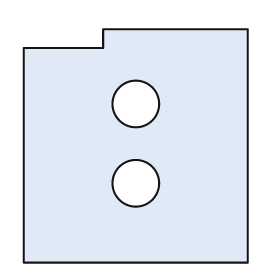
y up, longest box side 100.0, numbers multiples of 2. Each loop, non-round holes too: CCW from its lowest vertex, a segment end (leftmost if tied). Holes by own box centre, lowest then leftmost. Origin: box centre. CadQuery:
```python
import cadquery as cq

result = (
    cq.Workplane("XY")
    .moveTo(-48.0, -50.0)
    .lineTo(48.0, -50.0)
    .lineTo(48.0, 50.0)
    .lineTo(-14.0, 50.0)
    .lineTo(-14.0, 42.0)
    .lineTo(-48.0, 42.0)
    .close()
    .moveTo(0.0, -16.0)
    .circle(10.0)
    .moveTo(0.0, 18.0)
    .circle(10.0)
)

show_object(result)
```